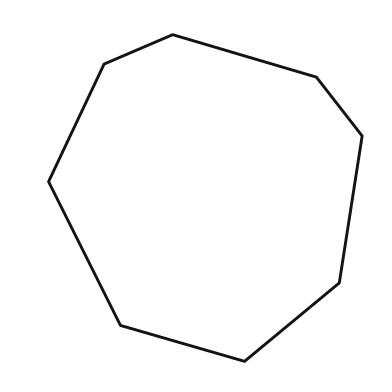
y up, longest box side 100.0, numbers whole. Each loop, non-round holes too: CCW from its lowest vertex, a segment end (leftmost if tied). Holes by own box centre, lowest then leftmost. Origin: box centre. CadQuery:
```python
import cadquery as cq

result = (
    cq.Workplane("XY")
    .moveTo(12.0, -50.0)
    .lineTo(41.0, -26.0)
    .lineTo(48.0, 19.0)
    .lineTo(34.0, 37.0)
    .lineTo(-10.0, 50.0)
    .lineTo(-31.0, 41.0)
    .lineTo(-48.0, 5.0)
    .lineTo(-26.0, -39.0)
    .close()
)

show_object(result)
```